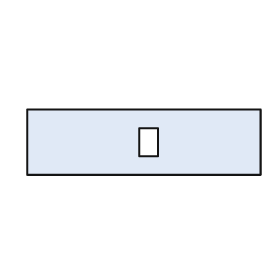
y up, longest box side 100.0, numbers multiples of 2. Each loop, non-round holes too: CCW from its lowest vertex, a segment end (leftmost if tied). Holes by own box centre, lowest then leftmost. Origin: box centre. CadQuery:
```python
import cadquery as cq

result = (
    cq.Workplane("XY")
    .moveTo(-50.0, -14.0)
    .lineTo(50.0, -14.0)
    .lineTo(50.0, 14.0)
    .lineTo(-50.0, 14.0)
    .close()
    .moveTo(-2.0, -6.0)
    .lineTo(6.0, -6.0)
    .lineTo(6.0, 6.0)
    .lineTo(-2.0, 6.0)
    .close()
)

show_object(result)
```